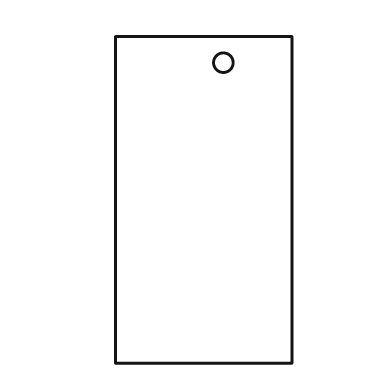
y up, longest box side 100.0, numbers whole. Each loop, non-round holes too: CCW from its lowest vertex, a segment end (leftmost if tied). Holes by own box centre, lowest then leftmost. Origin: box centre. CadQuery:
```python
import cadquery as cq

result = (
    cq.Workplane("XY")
    .moveTo(-27.0, -50.0)
    .lineTo(27.0, -50.0)
    .lineTo(27.0, 50.0)
    .lineTo(-27.0, 50.0)
    .close()
    .moveTo(6.0, 42.0)
    .circle(3.0)
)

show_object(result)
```